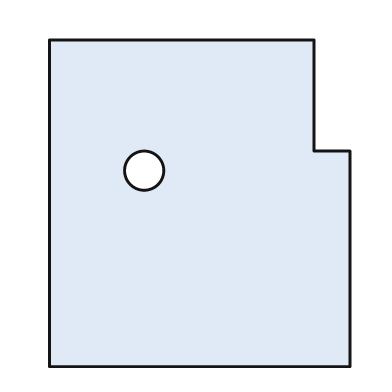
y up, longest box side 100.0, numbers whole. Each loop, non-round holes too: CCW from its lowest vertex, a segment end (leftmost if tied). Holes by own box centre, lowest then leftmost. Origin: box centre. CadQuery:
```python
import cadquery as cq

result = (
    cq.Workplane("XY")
    .moveTo(-46.0, -50.0)
    .lineTo(46.0, -50.0)
    .lineTo(46.0, 16.0)
    .lineTo(35.0, 16.0)
    .lineTo(35.0, 50.0)
    .lineTo(-46.0, 50.0)
    .close()
    .moveTo(-17.0, 10.0)
    .circle(6.0)
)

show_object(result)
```